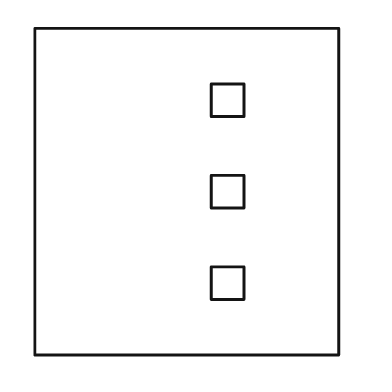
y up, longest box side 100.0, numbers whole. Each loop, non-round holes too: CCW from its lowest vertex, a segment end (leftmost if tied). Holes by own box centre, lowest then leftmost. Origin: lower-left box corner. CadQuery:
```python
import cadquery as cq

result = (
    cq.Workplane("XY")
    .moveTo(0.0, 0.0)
    .lineTo(93.0, 0.0)
    .lineTo(93.0, 100.0)
    .lineTo(0.0, 100.0)
    .close()
    .moveTo(54.0, 17.0)
    .lineTo(64.0, 17.0)
    .lineTo(64.0, 27.0)
    .lineTo(54.0, 27.0)
    .close()
    .moveTo(54.0, 45.0)
    .lineTo(64.0, 45.0)
    .lineTo(64.0, 55.0)
    .lineTo(54.0, 55.0)
    .close()
    .moveTo(54.0, 73.0)
    .lineTo(64.0, 73.0)
    .lineTo(64.0, 83.0)
    .lineTo(54.0, 83.0)
    .close()
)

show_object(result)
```